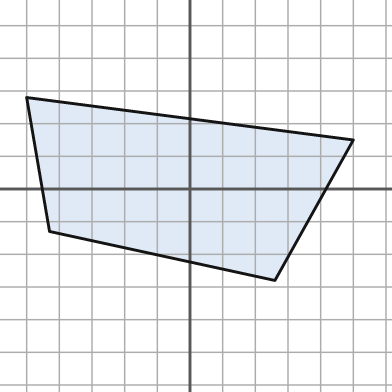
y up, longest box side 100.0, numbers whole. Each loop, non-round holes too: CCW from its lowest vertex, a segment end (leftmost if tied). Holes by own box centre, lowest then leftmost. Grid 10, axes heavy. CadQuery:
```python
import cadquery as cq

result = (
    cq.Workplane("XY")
    .moveTo(26.0, -28.0)
    .lineTo(50.0, 15.0)
    .lineTo(-50.0, 28.0)
    .lineTo(-43.0, -13.0)
    .close()
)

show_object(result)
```